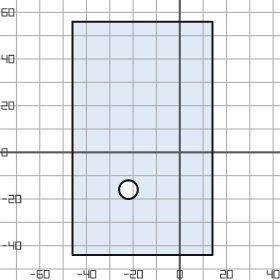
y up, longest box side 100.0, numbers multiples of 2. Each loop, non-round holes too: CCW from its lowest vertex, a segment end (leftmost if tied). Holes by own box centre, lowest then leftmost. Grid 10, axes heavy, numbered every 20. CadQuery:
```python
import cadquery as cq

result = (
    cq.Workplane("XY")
    .moveTo(-46.0, -44.0)
    .lineTo(14.0, -44.0)
    .lineTo(14.0, 56.0)
    .lineTo(-46.0, 56.0)
    .close()
    .moveTo(-22.0, -16.0)
    .circle(4.0)
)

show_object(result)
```